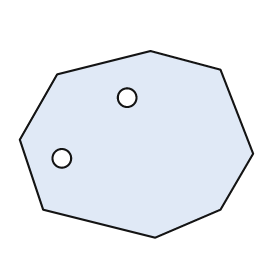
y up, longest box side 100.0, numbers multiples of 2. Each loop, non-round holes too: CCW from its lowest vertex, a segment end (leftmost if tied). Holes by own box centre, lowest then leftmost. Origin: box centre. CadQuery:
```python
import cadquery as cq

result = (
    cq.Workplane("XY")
    .moveTo(8.0, -40.0)
    .lineTo(36.0, -28.0)
    .lineTo(50.0, -4.0)
    .lineTo(36.0, 32.0)
    .lineTo(6.0, 40.0)
    .lineTo(-34.0, 30.0)
    .lineTo(-50.0, 2.0)
    .lineTo(-40.0, -28.0)
    .close()
    .moveTo(-32.0, -6.0)
    .circle(4.0)
    .moveTo(-4.0, 20.0)
    .circle(4.0)
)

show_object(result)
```